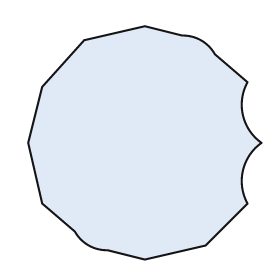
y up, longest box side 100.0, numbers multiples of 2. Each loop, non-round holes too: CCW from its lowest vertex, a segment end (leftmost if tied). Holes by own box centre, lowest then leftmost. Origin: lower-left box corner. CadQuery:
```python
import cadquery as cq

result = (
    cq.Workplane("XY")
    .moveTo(50.0, 0.0)
    .lineTo(76.0, 6.0)
    .lineTo(94.0, 24.0)
    .threePointArc((92.0, 38.0), (100.0, 50.0))
    .threePointArc((92.0, 62.0), (94.0, 76.0))
    .lineTo(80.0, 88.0)
    .threePointArc((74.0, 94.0), (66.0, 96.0))
    .lineTo(50.0, 100.0)
    .lineTo(24.0, 94.0)
    .lineTo(6.0, 74.0)
    .lineTo(0.0, 50.0)
    .lineTo(6.0, 24.0)
    .lineTo(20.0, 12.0)
    .threePointArc((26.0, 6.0), (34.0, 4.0))
    .close()
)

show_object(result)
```